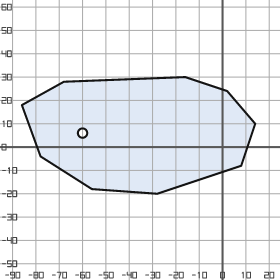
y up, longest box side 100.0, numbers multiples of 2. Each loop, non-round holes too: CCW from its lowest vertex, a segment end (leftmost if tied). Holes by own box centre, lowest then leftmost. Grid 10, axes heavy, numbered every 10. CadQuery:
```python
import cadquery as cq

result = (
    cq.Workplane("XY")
    .moveTo(-28.0, -20.0)
    .lineTo(8.0, -8.0)
    .lineTo(14.0, 10.0)
    .lineTo(2.0, 24.0)
    .lineTo(-16.0, 30.0)
    .lineTo(-68.0, 28.0)
    .lineTo(-86.0, 18.0)
    .lineTo(-78.0, -4.0)
    .lineTo(-56.0, -18.0)
    .close()
    .moveTo(-60.0, 6.0)
    .circle(2.0)
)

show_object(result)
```